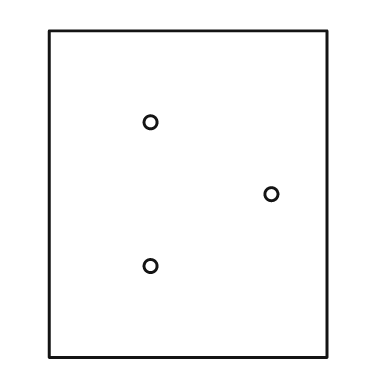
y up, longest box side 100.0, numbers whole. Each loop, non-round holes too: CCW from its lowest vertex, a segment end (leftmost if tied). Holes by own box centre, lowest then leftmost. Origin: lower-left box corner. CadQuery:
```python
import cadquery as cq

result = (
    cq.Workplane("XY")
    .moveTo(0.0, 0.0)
    .lineTo(85.0, 0.0)
    .lineTo(85.0, 100.0)
    .lineTo(0.0, 100.0)
    .close()
    .moveTo(31.0, 28.0)
    .circle(2.0)
    .moveTo(68.0, 50.0)
    .circle(2.0)
    .moveTo(31.0, 72.0)
    .circle(2.0)
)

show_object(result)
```